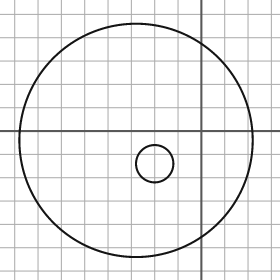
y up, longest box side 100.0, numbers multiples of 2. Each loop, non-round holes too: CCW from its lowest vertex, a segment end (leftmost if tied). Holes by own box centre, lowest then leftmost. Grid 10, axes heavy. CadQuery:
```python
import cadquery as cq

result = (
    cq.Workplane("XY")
    .moveTo(-28.0, -4.0)
    .circle(50.0)
    .moveTo(-20.0, -14.0)
    .circle(8.0)
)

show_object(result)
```